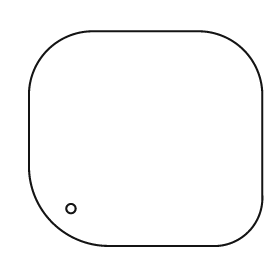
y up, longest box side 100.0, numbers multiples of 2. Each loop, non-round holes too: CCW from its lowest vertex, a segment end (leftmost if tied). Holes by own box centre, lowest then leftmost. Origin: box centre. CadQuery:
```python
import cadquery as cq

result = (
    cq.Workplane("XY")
    .moveTo(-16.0, -46.0)
    .lineTo(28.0, -46.0)
    .threePointArc((44.0, -40.0), (50.0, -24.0))
    .lineTo(50.0, 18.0)
    .threePointArc((42.0, 38.0), (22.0, 46.0))
    .lineTo(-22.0, 46.0)
    .threePointArc((-42.0, 38.0), (-50.0, 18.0))
    .lineTo(-50.0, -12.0)
    .threePointArc((-40.0, -36.0), (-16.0, -46.0))
    .close()
    .moveTo(-32.0, -30.0)
    .circle(2.0)
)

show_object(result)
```